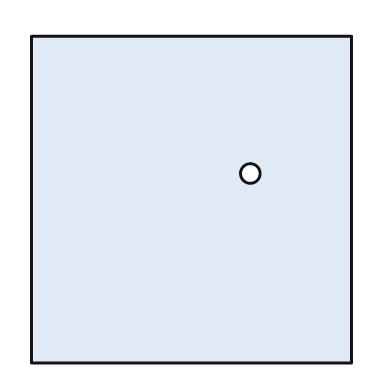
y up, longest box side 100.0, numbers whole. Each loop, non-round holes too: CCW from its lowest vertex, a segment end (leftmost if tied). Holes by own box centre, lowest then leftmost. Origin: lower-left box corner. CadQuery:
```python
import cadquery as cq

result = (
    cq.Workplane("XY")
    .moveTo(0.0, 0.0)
    .lineTo(98.0, 0.0)
    .lineTo(98.0, 100.0)
    .lineTo(0.0, 100.0)
    .close()
    .moveTo(67.0, 58.0)
    .circle(3.0)
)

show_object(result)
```